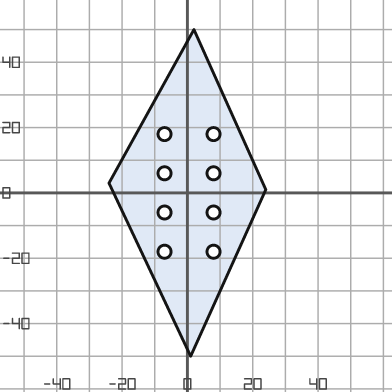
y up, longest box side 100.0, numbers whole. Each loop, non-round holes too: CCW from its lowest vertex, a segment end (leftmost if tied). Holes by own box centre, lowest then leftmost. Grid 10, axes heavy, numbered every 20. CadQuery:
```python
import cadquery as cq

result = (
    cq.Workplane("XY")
    .moveTo(1.0, -50.0)
    .lineTo(24.0, 1.0)
    .lineTo(2.0, 50.0)
    .lineTo(-24.0, 3.0)
    .close()
    .moveTo(-7.0, -18.0)
    .circle(2.0)
    .moveTo(8.0, -18.0)
    .circle(2.0)
    .moveTo(-7.0, -6.0)
    .circle(2.0)
    .moveTo(8.0, -6.0)
    .circle(2.0)
    .moveTo(-7.0, 6.0)
    .circle(2.0)
    .moveTo(8.0, 6.0)
    .circle(2.0)
    .moveTo(-7.0, 18.0)
    .circle(2.0)
    .moveTo(8.0, 18.0)
    .circle(2.0)
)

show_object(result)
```